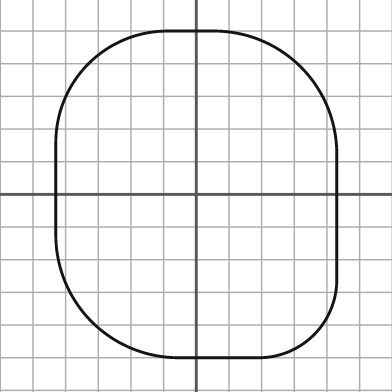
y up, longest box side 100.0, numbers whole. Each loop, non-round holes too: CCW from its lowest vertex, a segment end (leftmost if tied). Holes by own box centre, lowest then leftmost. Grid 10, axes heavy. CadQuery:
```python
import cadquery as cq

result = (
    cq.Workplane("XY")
    .moveTo(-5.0, -50.0)
    .lineTo(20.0, -50.0)
    .threePointArc((36.0, -43.0), (43.0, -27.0))
    .lineTo(43.0, 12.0)
    .threePointArc((32.0, 39.0), (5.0, 50.0))
    .lineTo(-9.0, 50.0)
    .threePointArc((-33.0, 40.0), (-43.0, 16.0))
    .lineTo(-43.0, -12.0)
    .threePointArc((-32.0, -39.0), (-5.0, -50.0))
    .close()
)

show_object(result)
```